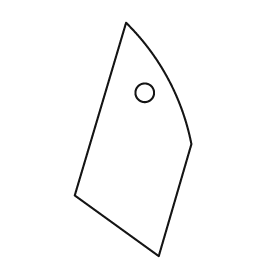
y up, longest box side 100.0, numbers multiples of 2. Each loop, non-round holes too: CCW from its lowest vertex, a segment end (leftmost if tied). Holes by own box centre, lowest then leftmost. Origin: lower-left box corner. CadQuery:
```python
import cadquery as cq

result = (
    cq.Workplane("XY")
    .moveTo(36.0, 0.0)
    .lineTo(50.0, 48.0)
    .threePointArc((40.0, 76.0), (22.0, 100.0))
    .lineTo(0.0, 26.0)
    .close()
    .moveTo(30.0, 70.0)
    .circle(4.0)
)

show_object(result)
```